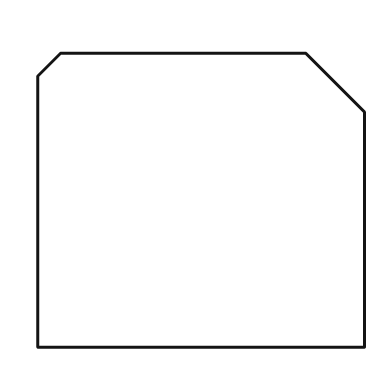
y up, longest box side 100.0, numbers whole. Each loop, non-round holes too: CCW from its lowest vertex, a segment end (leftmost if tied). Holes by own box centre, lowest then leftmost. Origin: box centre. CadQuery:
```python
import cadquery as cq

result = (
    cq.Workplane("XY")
    .moveTo(-50.0, -45.0)
    .lineTo(50.0, -45.0)
    .lineTo(50.0, 27.0)
    .lineTo(32.0, 45.0)
    .lineTo(-43.0, 45.0)
    .lineTo(-50.0, 38.0)
    .close()
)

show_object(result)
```